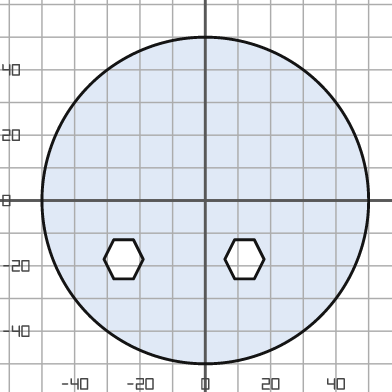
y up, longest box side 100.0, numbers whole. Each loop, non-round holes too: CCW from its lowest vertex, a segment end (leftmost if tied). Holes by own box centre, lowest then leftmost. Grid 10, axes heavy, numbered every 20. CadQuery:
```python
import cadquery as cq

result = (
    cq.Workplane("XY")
    .moveTo(0.0, 0.0)
    .circle(50.0)
    .moveTo(-28.0, -24.0)
    .lineTo(-22.0, -24.0)
    .lineTo(-19.0, -18.0)
    .lineTo(-22.0, -12.0)
    .lineTo(-28.0, -12.0)
    .lineTo(-31.0, -18.0)
    .close()
    .moveTo(9.0, -24.0)
    .lineTo(15.0, -24.0)
    .lineTo(18.0, -18.0)
    .lineTo(15.0, -12.0)
    .lineTo(9.0, -12.0)
    .lineTo(6.0, -18.0)
    .close()
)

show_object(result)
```